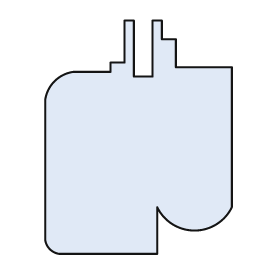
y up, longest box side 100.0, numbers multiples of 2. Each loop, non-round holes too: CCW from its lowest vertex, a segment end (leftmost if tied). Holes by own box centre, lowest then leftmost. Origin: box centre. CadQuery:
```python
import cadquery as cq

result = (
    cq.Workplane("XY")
    .moveTo(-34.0, -50.0)
    .lineTo(8.0, -50.0)
    .lineTo(8.0, -30.0)
    .threePointArc((24.0, -40.0), (40.0, -30.0))
    .lineTo(40.0, 30.0)
    .lineTo(16.0, 30.0)
    .lineTo(16.0, 42.0)
    .lineTo(10.0, 42.0)
    .lineTo(10.0, 50.0)
    .lineTo(6.0, 50.0)
    .lineTo(6.0, 26.0)
    .lineTo(-2.0, 26.0)
    .lineTo(-2.0, 50.0)
    .lineTo(-6.0, 50.0)
    .lineTo(-6.0, 32.0)
    .lineTo(-12.0, 32.0)
    .lineTo(-12.0, 28.0)
    .lineTo(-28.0, 28.0)
    .threePointArc((-36.0, 24.0), (-40.0, 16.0))
    .lineTo(-40.0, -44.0)
    .threePointArc((-38.0, -48.0), (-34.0, -50.0))
    .close()
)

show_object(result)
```